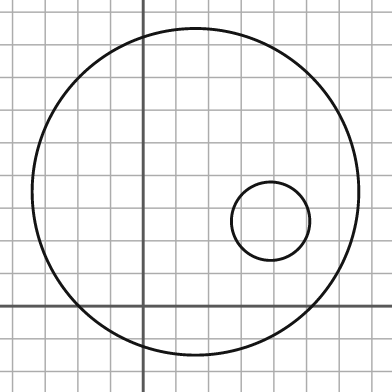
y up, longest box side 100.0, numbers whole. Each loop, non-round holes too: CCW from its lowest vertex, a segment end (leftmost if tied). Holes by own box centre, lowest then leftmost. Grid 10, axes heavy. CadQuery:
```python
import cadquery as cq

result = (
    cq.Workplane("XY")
    .moveTo(16.0, 35.0)
    .circle(50.0)
    .moveTo(39.0, 26.0)
    .circle(12.0)
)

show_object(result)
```